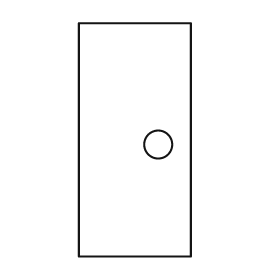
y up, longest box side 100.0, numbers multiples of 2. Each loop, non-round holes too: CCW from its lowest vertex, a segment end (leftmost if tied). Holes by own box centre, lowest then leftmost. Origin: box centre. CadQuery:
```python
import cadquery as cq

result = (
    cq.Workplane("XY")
    .moveTo(-24.0, -50.0)
    .lineTo(24.0, -50.0)
    .lineTo(24.0, 50.0)
    .lineTo(-24.0, 50.0)
    .close()
    .moveTo(10.0, -2.0)
    .circle(6.0)
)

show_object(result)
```